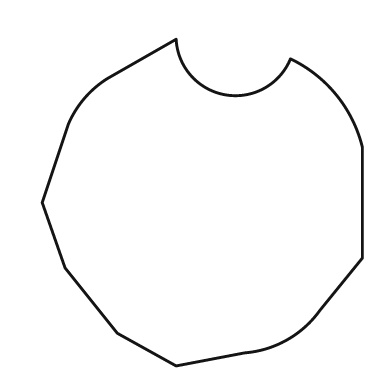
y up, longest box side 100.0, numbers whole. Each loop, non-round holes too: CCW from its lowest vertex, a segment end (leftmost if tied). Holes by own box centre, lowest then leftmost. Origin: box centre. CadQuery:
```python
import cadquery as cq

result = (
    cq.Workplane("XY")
    .moveTo(-8.0, -50.0)
    .lineTo(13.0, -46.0)
    .threePointArc((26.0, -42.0), (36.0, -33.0))
    .lineTo(49.0, -17.0)
    .lineTo(49.0, 17.0)
    .threePointArc((41.0, 33.0), (27.0, 44.0))
    .threePointArc((7.0, 33.0), (-8.0, 50.0))
    .lineTo(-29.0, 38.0)
    .threePointArc((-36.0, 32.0), (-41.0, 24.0))
    .lineTo(-49.0, 0.0)
    .lineTo(-42.0, -20.0)
    .lineTo(-26.0, -40.0)
    .close()
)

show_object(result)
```